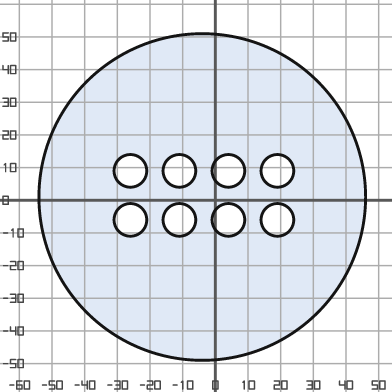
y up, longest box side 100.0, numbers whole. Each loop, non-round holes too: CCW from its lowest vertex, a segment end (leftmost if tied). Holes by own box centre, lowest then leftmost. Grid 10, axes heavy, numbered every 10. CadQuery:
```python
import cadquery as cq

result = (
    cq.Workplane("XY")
    .moveTo(-4.0, 1.0)
    .circle(50.0)
    .moveTo(-26.0, -6.0)
    .circle(5.0)
    .moveTo(-11.0, -6.0)
    .circle(5.0)
    .moveTo(4.0, -6.0)
    .circle(5.0)
    .moveTo(19.0, -6.0)
    .circle(5.0)
    .moveTo(-26.0, 9.0)
    .circle(5.0)
    .moveTo(-11.0, 9.0)
    .circle(5.0)
    .moveTo(4.0, 9.0)
    .circle(5.0)
    .moveTo(19.0, 9.0)
    .circle(5.0)
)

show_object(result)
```